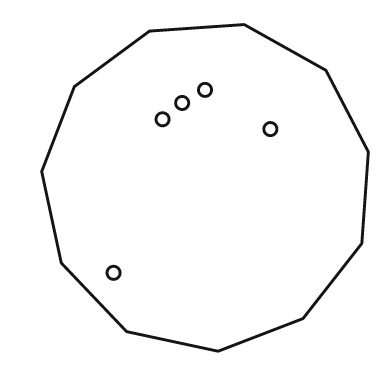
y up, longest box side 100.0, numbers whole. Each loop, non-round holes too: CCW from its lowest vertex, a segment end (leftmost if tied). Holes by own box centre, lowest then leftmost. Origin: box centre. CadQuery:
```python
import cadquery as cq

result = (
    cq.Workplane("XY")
    .moveTo(4.0, -50.0)
    .lineTo(30.0, -40.0)
    .lineTo(48.0, -17.0)
    .lineTo(50.0, 11.0)
    .lineTo(37.0, 36.0)
    .lineTo(12.0, 50.0)
    .lineTo(-17.0, 48.0)
    .lineTo(-40.0, 31.0)
    .lineTo(-50.0, 5.0)
    .lineTo(-44.0, -23.0)
    .lineTo(-24.0, -44.0)
    .close()
    .moveTo(-28.0, -26.0)
    .circle(2.0)
    .moveTo(20.0, 18.0)
    .circle(2.0)
    .moveTo(-13.0, 21.0)
    .circle(2.0)
    .moveTo(-7.0, 26.0)
    .circle(2.0)
    .moveTo(0.0, 30.0)
    .circle(2.0)
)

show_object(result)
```